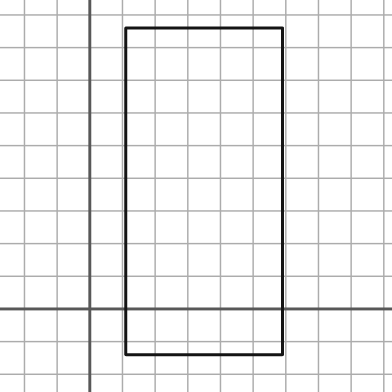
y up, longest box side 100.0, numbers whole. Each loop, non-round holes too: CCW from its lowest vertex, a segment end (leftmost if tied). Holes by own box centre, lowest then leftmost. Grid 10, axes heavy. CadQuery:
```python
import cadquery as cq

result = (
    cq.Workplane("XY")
    .moveTo(11.0, -14.0)
    .lineTo(59.0, -14.0)
    .lineTo(59.0, 86.0)
    .lineTo(11.0, 86.0)
    .close()
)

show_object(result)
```